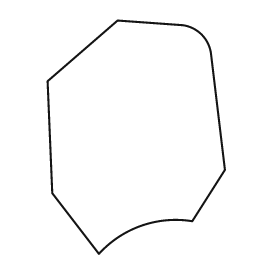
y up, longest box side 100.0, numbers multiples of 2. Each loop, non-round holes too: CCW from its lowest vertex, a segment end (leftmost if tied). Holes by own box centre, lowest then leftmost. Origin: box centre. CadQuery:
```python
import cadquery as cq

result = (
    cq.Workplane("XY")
    .moveTo(-16.0, -50.0)
    .threePointArc((2.0, -38.0), (24.0, -36.0))
    .lineTo(38.0, -14.0)
    .lineTo(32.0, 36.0)
    .threePointArc((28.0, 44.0), (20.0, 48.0))
    .lineTo(-8.0, 50.0)
    .lineTo(-38.0, 24.0)
    .lineTo(-36.0, -24.0)
    .close()
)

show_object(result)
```